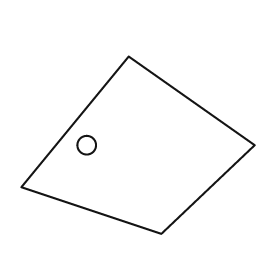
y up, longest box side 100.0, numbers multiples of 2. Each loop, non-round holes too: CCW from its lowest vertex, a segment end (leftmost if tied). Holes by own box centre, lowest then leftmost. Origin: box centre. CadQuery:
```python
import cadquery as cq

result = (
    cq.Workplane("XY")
    .moveTo(10.0, -38.0)
    .lineTo(50.0, 0.0)
    .lineTo(-4.0, 38.0)
    .lineTo(-50.0, -18.0)
    .close()
    .moveTo(-22.0, 0.0)
    .circle(4.0)
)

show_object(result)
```